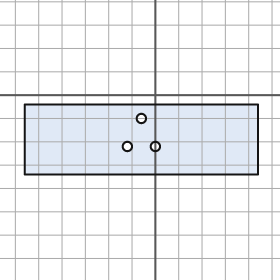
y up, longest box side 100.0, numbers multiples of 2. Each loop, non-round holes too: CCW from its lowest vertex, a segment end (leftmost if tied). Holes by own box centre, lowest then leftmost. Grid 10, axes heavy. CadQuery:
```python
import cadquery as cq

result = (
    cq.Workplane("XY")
    .moveTo(-56.0, -34.0)
    .lineTo(44.0, -34.0)
    .lineTo(44.0, -4.0)
    .lineTo(-56.0, -4.0)
    .close()
    .moveTo(-12.0, -22.0)
    .circle(2.0)
    .moveTo(0.0, -22.0)
    .circle(2.0)
    .moveTo(-6.0, -10.0)
    .circle(2.0)
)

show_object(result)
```